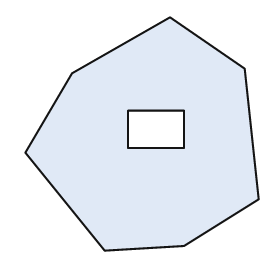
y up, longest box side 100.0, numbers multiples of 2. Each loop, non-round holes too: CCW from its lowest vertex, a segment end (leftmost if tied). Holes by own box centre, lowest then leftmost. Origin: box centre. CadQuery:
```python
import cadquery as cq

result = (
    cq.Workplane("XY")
    .moveTo(-16.0, -50.0)
    .lineTo(18.0, -48.0)
    .lineTo(50.0, -28.0)
    .lineTo(44.0, 28.0)
    .lineTo(12.0, 50.0)
    .lineTo(-30.0, 26.0)
    .lineTo(-50.0, -8.0)
    .close()
    .moveTo(-6.0, -6.0)
    .lineTo(18.0, -6.0)
    .lineTo(18.0, 10.0)
    .lineTo(-6.0, 10.0)
    .close()
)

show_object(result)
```